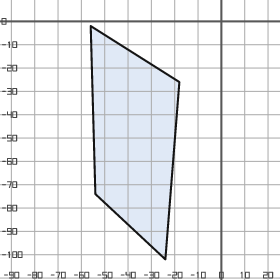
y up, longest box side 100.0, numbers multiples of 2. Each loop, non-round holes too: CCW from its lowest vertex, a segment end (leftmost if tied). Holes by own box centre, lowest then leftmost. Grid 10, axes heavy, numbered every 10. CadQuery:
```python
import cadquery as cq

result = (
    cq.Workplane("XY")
    .moveTo(-24.0, -102.0)
    .lineTo(-18.0, -26.0)
    .lineTo(-56.0, -2.0)
    .lineTo(-54.0, -74.0)
    .close()
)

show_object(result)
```